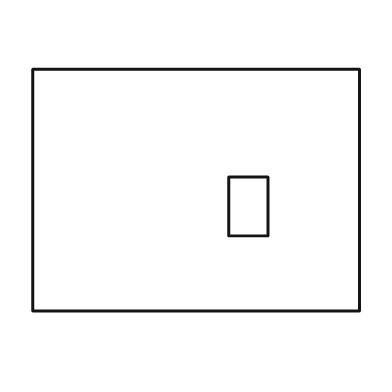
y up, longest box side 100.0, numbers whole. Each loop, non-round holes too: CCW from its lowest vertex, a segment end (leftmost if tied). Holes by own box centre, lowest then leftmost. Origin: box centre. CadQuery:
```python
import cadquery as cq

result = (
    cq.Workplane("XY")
    .moveTo(-50.0, -37.0)
    .lineTo(50.0, -37.0)
    .lineTo(50.0, 37.0)
    .lineTo(-50.0, 37.0)
    .close()
    .moveTo(10.0, -14.0)
    .lineTo(22.0, -14.0)
    .lineTo(22.0, 4.0)
    .lineTo(10.0, 4.0)
    .close()
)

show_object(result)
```